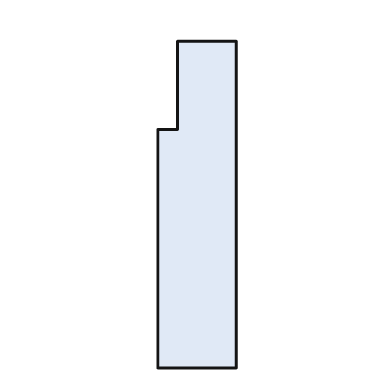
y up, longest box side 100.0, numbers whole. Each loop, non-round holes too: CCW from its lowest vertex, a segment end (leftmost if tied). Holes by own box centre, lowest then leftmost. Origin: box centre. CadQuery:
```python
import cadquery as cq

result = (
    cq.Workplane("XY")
    .moveTo(-12.0, -50.0)
    .lineTo(12.0, -50.0)
    .lineTo(12.0, 50.0)
    .lineTo(-6.0, 50.0)
    .lineTo(-6.0, 23.0)
    .lineTo(-12.0, 23.0)
    .close()
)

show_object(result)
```